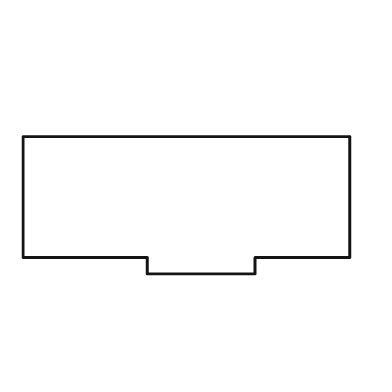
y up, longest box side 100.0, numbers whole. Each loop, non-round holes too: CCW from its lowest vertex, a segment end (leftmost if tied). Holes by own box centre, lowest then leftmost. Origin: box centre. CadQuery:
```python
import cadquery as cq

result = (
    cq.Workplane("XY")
    .moveTo(-12.0, -21.0)
    .lineTo(21.0, -21.0)
    .lineTo(21.0, -16.0)
    .lineTo(50.0, -16.0)
    .lineTo(50.0, 21.0)
    .lineTo(-50.0, 21.0)
    .lineTo(-50.0, -16.0)
    .lineTo(-12.0, -16.0)
    .close()
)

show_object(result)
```